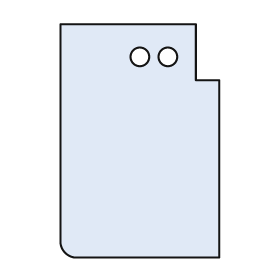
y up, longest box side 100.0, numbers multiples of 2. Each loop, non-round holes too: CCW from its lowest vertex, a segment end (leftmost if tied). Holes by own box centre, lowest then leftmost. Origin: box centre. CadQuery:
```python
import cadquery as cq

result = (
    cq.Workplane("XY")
    .moveTo(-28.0, -50.0)
    .lineTo(34.0, -50.0)
    .lineTo(34.0, 26.0)
    .lineTo(24.0, 26.0)
    .lineTo(24.0, 50.0)
    .lineTo(-34.0, 50.0)
    .lineTo(-34.0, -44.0)
    .threePointArc((-32.0, -48.0), (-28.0, -50.0))
    .close()
    .moveTo(0.0, 36.0)
    .circle(4.0)
    .moveTo(12.0, 36.0)
    .circle(4.0)
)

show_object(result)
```